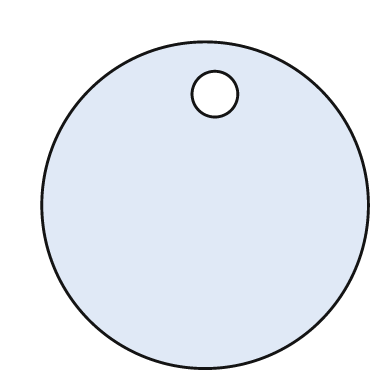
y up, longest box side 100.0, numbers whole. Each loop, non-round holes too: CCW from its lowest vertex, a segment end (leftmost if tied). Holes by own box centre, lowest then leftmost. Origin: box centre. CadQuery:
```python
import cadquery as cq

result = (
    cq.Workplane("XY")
    .moveTo(0.0, 0.0)
    .circle(50.0)
    .moveTo(3.0, 34.0)
    .circle(7.0)
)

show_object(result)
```